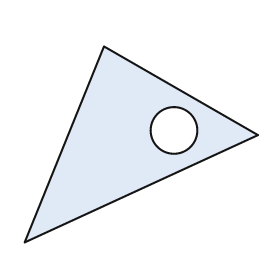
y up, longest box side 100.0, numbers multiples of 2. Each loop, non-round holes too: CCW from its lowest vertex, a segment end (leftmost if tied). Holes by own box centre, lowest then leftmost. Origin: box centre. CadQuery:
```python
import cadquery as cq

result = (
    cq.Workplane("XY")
    .moveTo(-50.0, -42.0)
    .lineTo(50.0, 4.0)
    .lineTo(-16.0, 42.0)
    .close()
    .moveTo(14.0, 6.0)
    .circle(10.0)
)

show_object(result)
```